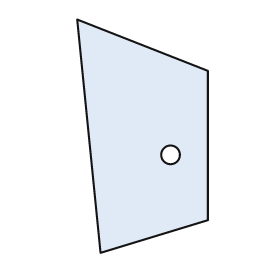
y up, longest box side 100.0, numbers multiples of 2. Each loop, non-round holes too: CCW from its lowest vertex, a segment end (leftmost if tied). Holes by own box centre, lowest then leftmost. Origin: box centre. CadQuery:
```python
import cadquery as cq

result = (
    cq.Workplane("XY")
    .moveTo(-18.0, -50.0)
    .lineTo(28.0, -36.0)
    .lineTo(28.0, 28.0)
    .lineTo(-28.0, 50.0)
    .close()
    .moveTo(12.0, -8.0)
    .circle(4.0)
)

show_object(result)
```